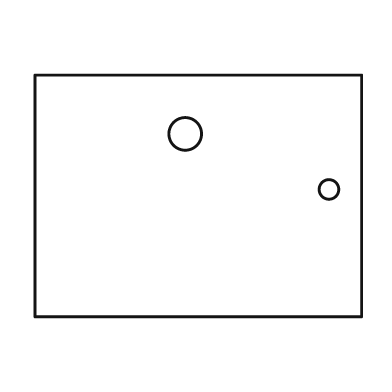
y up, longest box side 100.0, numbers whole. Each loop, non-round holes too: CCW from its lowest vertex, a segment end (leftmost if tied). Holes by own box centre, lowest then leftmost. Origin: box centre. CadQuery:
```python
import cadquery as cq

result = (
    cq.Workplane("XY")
    .moveTo(-50.0, -37.0)
    .lineTo(50.0, -37.0)
    .lineTo(50.0, 37.0)
    .lineTo(-50.0, 37.0)
    .close()
    .moveTo(40.0, 2.0)
    .circle(3.0)
    .moveTo(-4.0, 19.0)
    .circle(5.0)
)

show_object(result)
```